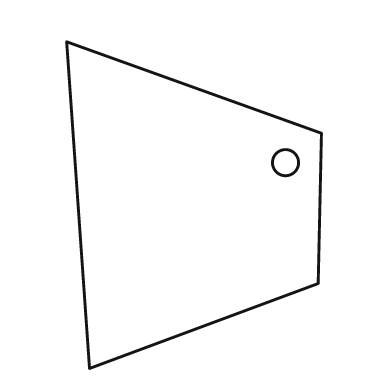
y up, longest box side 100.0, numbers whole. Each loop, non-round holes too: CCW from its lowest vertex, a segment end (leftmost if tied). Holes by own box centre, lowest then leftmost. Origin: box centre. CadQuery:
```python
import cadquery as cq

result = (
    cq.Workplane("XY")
    .moveTo(-32.0, -50.0)
    .lineTo(38.0, -24.0)
    .lineTo(39.0, 22.0)
    .lineTo(-39.0, 50.0)
    .close()
    .moveTo(28.0, 13.0)
    .circle(4.0)
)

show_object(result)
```